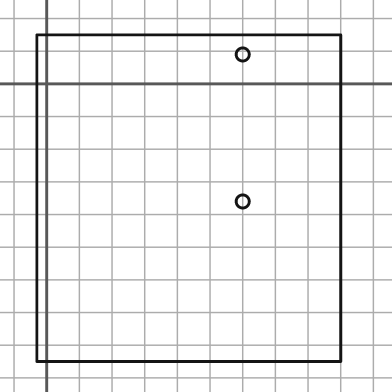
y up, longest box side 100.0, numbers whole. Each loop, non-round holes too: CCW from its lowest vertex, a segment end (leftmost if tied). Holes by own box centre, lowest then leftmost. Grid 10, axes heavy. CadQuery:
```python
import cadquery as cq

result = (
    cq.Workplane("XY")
    .moveTo(-3.0, -85.0)
    .lineTo(90.0, -85.0)
    .lineTo(90.0, 15.0)
    .lineTo(-3.0, 15.0)
    .close()
    .moveTo(60.0, -36.0)
    .circle(2.0)
    .moveTo(60.0, 9.0)
    .circle(2.0)
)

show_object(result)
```